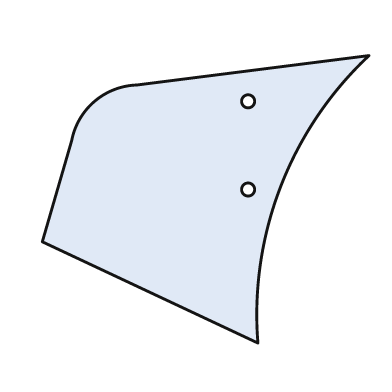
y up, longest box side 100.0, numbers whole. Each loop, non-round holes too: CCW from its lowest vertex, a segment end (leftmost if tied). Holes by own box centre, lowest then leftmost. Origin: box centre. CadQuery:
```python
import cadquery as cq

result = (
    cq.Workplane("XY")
    .moveTo(16.0, -44.0)
    .threePointArc((23.0, 4.0), (50.0, 44.0))
    .lineTo(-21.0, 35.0)
    .threePointArc((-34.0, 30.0), (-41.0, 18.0))
    .lineTo(-50.0, -13.0)
    .close()
    .moveTo(13.0, 3.0)
    .circle(2.0)
    .moveTo(13.0, 30.0)
    .circle(2.0)
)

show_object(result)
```